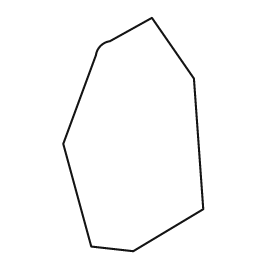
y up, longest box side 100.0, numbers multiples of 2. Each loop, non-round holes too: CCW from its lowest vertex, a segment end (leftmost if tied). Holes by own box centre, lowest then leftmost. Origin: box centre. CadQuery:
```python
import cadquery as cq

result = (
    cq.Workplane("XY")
    .moveTo(0.0, -50.0)
    .lineTo(30.0, -32.0)
    .lineTo(26.0, 24.0)
    .lineTo(8.0, 50.0)
    .lineTo(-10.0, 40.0)
    .threePointArc((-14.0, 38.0), (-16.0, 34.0))
    .lineTo(-30.0, -4.0)
    .lineTo(-18.0, -48.0)
    .close()
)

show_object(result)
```